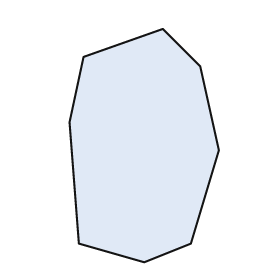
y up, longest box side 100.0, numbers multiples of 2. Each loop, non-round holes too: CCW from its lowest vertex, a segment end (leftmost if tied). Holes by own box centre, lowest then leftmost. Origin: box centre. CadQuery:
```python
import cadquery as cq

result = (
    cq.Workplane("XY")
    .moveTo(0.0, -50.0)
    .lineTo(20.0, -42.0)
    .lineTo(32.0, -2.0)
    .lineTo(24.0, 34.0)
    .lineTo(8.0, 50.0)
    .lineTo(-26.0, 38.0)
    .lineTo(-32.0, 10.0)
    .lineTo(-28.0, -42.0)
    .close()
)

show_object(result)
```